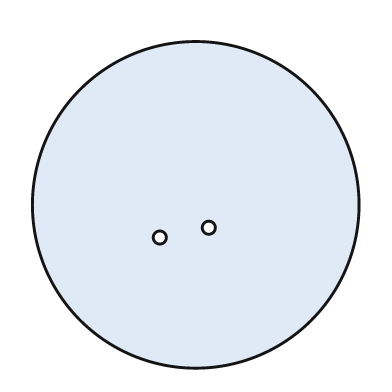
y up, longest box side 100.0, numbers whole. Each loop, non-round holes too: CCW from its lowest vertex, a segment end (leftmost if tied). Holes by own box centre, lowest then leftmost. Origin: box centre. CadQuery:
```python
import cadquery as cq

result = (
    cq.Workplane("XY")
    .moveTo(0.0, 0.0)
    .circle(50.0)
    .moveTo(-11.0, -10.0)
    .circle(2.0)
    .moveTo(4.0, -7.0)
    .circle(2.0)
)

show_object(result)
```